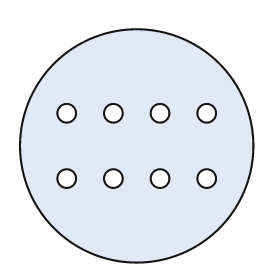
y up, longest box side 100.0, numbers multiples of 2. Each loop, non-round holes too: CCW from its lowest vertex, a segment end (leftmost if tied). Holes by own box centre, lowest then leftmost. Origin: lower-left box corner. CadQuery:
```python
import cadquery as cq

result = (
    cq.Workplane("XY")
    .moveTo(50.0, 50.0)
    .circle(50.0)
    .moveTo(20.0, 36.0)
    .circle(4.0)
    .moveTo(40.0, 36.0)
    .circle(4.0)
    .moveTo(60.0, 36.0)
    .circle(4.0)
    .moveTo(80.0, 36.0)
    .circle(4.0)
    .moveTo(20.0, 64.0)
    .circle(4.0)
    .moveTo(40.0, 64.0)
    .circle(4.0)
    .moveTo(60.0, 64.0)
    .circle(4.0)
    .moveTo(80.0, 64.0)
    .circle(4.0)
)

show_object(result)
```